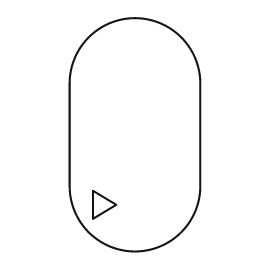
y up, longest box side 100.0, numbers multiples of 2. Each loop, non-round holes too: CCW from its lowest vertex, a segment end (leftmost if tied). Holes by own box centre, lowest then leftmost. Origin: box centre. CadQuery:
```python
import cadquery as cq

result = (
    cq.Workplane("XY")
    .moveTo(-28.0, -22.0)
    .threePointArc((0.0, -50.0), (28.0, -22.0))
    .lineTo(28.0, 22.0)
    .threePointArc((0.0, 50.0), (-28.0, 22.0))
    .close()
    .moveTo(-18.0, -36.0)
    .lineTo(-8.0, -30.0)
    .lineTo(-18.0, -24.0)
    .close()
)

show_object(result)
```